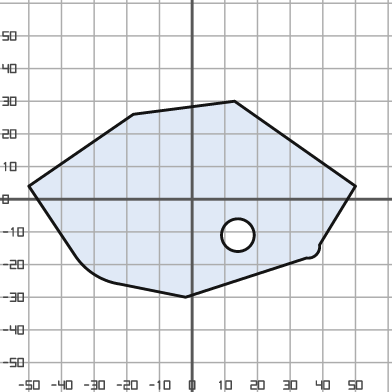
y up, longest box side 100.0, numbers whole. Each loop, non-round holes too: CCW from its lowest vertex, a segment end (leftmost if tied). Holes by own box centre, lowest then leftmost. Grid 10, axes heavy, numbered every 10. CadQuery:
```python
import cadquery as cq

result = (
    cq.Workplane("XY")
    .moveTo(-2.0, -30.0)
    .lineTo(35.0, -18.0)
    .threePointArc((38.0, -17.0), (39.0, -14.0))
    .lineTo(50.0, 4.0)
    .lineTo(13.0, 30.0)
    .lineTo(-18.0, 26.0)
    .lineTo(-50.0, 4.0)
    .lineTo(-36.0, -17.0)
    .threePointArc((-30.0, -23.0), (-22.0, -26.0))
    .close()
    .moveTo(14.0, -11.0)
    .circle(5.0)
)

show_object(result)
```